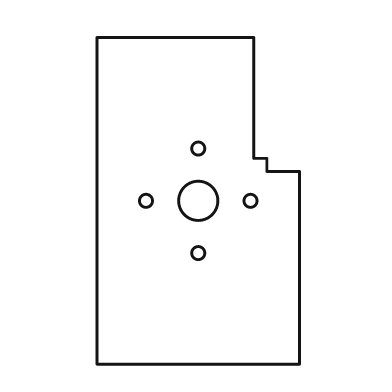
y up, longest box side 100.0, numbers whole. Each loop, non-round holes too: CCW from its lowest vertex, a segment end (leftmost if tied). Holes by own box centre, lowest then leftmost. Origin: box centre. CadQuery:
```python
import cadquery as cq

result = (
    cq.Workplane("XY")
    .moveTo(-31.0, -50.0)
    .lineTo(31.0, -50.0)
    .lineTo(31.0, 9.0)
    .lineTo(21.0, 9.0)
    .lineTo(21.0, 13.0)
    .lineTo(17.0, 13.0)
    .lineTo(17.0, 50.0)
    .lineTo(-31.0, 50.0)
    .close()
    .moveTo(0.0, -16.0)
    .circle(2.0)
    .moveTo(-16.0, 0.0)
    .circle(2.0)
    .moveTo(0.0, 0.0)
    .circle(6.0)
    .moveTo(16.0, 0.0)
    .circle(2.0)
    .moveTo(0.0, 16.0)
    .circle(2.0)
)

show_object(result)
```